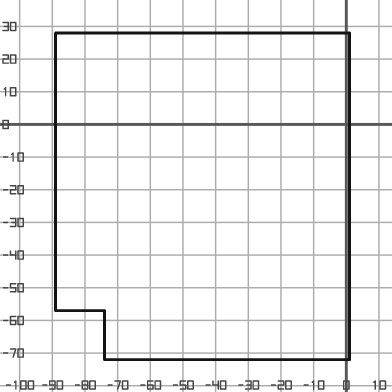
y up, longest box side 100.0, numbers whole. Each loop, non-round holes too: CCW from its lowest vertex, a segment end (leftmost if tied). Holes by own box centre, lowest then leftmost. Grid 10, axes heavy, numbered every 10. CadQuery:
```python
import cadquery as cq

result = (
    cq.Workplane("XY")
    .moveTo(-74.0, -72.0)
    .lineTo(1.0, -72.0)
    .lineTo(1.0, 28.0)
    .lineTo(-89.0, 28.0)
    .lineTo(-89.0, -57.0)
    .lineTo(-74.0, -57.0)
    .close()
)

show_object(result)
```